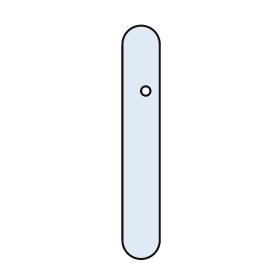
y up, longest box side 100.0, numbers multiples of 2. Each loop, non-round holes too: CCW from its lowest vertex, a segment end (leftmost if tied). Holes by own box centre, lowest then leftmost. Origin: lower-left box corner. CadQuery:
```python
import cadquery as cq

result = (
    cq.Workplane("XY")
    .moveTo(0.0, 8.0)
    .threePointArc((8.0, 0.0), (16.0, 8.0))
    .lineTo(16.0, 92.0)
    .threePointArc((8.0, 100.0), (0.0, 92.0))
    .close()
    .moveTo(10.0, 72.0)
    .circle(2.0)
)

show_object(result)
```